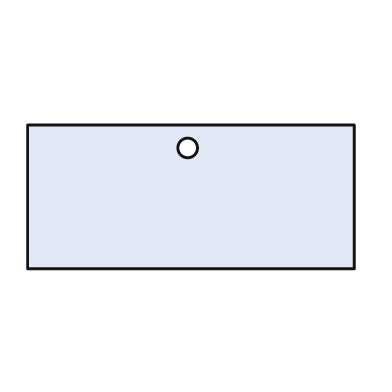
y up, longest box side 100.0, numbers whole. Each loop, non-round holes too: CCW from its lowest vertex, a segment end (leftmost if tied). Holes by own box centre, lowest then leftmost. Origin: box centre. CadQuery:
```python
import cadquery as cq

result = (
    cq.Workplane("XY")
    .moveTo(-50.0, -22.0)
    .lineTo(50.0, -22.0)
    .lineTo(50.0, 22.0)
    .lineTo(-50.0, 22.0)
    .close()
    .moveTo(-1.0, 15.0)
    .circle(3.0)
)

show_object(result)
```